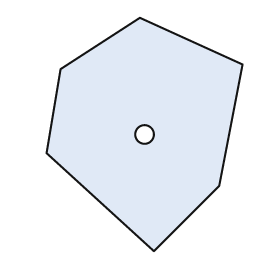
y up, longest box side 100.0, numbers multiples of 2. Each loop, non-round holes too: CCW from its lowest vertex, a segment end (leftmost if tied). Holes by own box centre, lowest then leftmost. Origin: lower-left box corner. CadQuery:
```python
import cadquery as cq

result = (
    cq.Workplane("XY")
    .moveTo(46.0, 0.0)
    .lineTo(74.0, 28.0)
    .lineTo(84.0, 80.0)
    .lineTo(40.0, 100.0)
    .lineTo(6.0, 78.0)
    .lineTo(0.0, 42.0)
    .close()
    .moveTo(42.0, 50.0)
    .circle(4.0)
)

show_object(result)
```